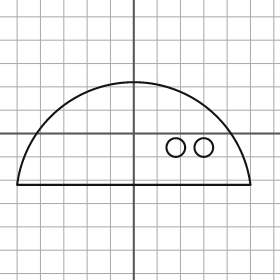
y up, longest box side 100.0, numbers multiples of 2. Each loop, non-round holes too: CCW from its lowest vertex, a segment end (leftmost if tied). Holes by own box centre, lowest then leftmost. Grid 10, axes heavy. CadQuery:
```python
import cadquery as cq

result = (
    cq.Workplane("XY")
    .moveTo(-50.0, -22.0)
    .lineTo(50.0, -22.0)
    .threePointArc((0.0, 22.0), (-50.0, -22.0))
    .close()
    .moveTo(18.0, -6.0)
    .circle(4.0)
    .moveTo(30.0, -6.0)
    .circle(4.0)
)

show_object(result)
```